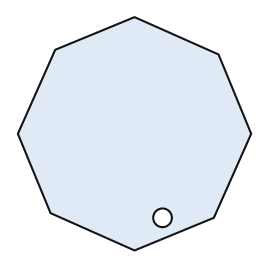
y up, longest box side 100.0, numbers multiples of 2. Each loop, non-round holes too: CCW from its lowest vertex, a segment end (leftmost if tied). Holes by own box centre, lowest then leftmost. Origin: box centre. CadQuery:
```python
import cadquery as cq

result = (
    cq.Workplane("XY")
    .moveTo(0.0, -50.0)
    .lineTo(34.0, -36.0)
    .lineTo(50.0, 0.0)
    .lineTo(36.0, 34.0)
    .lineTo(0.0, 50.0)
    .lineTo(-34.0, 36.0)
    .lineTo(-50.0, 0.0)
    .lineTo(-36.0, -34.0)
    .close()
    .moveTo(12.0, -36.0)
    .circle(4.0)
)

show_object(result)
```